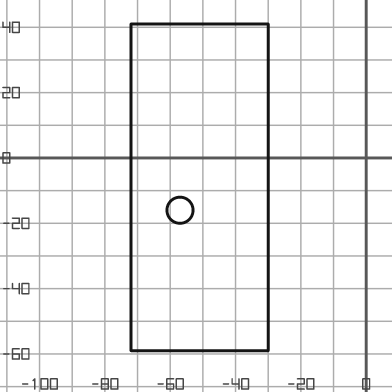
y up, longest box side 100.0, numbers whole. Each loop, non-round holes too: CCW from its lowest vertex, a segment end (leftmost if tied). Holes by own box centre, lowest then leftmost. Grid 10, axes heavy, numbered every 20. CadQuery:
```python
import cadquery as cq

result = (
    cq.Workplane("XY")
    .moveTo(-72.0, -59.0)
    .lineTo(-30.0, -59.0)
    .lineTo(-30.0, 41.0)
    .lineTo(-72.0, 41.0)
    .close()
    .moveTo(-57.0, -16.0)
    .circle(4.0)
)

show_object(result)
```